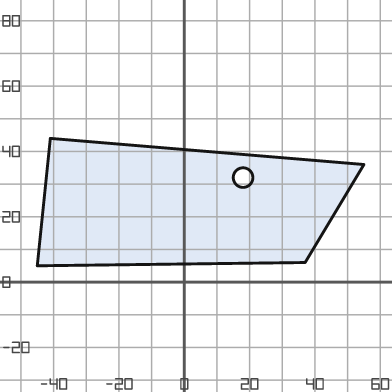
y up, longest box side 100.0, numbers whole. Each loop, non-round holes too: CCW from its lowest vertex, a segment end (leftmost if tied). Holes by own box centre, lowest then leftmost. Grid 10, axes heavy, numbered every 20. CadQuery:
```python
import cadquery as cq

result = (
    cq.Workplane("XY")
    .moveTo(-45.0, 5.0)
    .lineTo(37.0, 6.0)
    .lineTo(55.0, 36.0)
    .lineTo(-41.0, 44.0)
    .close()
    .moveTo(18.0, 32.0)
    .circle(3.0)
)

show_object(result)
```